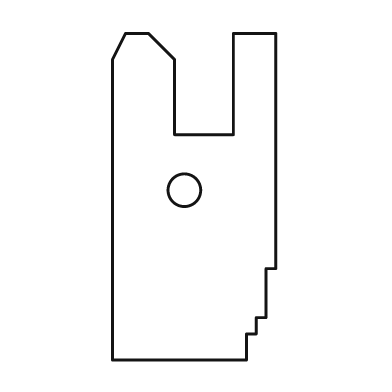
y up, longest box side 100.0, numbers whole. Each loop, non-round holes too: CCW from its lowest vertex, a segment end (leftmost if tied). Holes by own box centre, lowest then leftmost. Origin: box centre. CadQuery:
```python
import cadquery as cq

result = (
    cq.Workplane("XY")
    .moveTo(-25.0, -50.0)
    .lineTo(16.0, -50.0)
    .lineTo(16.0, -42.0)
    .lineTo(19.0, -42.0)
    .lineTo(19.0, -37.0)
    .lineTo(22.0, -37.0)
    .lineTo(22.0, -22.0)
    .lineTo(25.0, -22.0)
    .lineTo(25.0, 50.0)
    .lineTo(12.0, 50.0)
    .lineTo(12.0, 19.0)
    .lineTo(-6.0, 19.0)
    .lineTo(-6.0, 42.0)
    .lineTo(-14.0, 50.0)
    .lineTo(-21.0, 50.0)
    .lineTo(-25.0, 42.0)
    .close()
    .moveTo(-3.0, 2.0)
    .circle(5.0)
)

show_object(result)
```